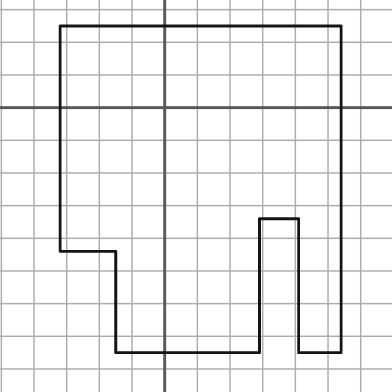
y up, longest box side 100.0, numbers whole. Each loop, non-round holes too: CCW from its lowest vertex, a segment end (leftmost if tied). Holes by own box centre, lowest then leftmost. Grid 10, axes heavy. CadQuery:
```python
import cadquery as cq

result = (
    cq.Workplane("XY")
    .moveTo(-15.0, -75.0)
    .lineTo(29.0, -75.0)
    .lineTo(29.0, -34.0)
    .lineTo(41.0, -34.0)
    .lineTo(41.0, -75.0)
    .lineTo(54.0, -75.0)
    .lineTo(54.0, 25.0)
    .lineTo(-32.0, 25.0)
    .lineTo(-32.0, -44.0)
    .lineTo(-15.0, -44.0)
    .close()
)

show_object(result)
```